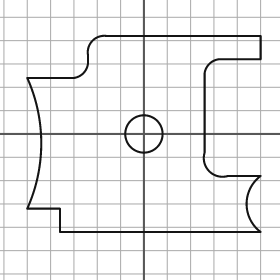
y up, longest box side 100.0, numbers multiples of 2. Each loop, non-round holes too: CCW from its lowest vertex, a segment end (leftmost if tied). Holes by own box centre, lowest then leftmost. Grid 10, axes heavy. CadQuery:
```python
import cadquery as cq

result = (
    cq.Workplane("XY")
    .moveTo(-36.0, -42.0)
    .lineTo(50.0, -42.0)
    .threePointArc((44.0, -30.0), (50.0, -18.0))
    .lineTo(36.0, -18.0)
    .threePointArc((28.0, -16.0), (26.0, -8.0))
    .lineTo(26.0, 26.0)
    .threePointArc((28.0, 30.0), (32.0, 32.0))
    .lineTo(50.0, 32.0)
    .lineTo(50.0, 42.0)
    .lineTo(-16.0, 42.0)
    .threePointArc((-22.0, 40.0), (-24.0, 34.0))
    .lineTo(-24.0, 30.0)
    .threePointArc((-26.0, 26.0), (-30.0, 24.0))
    .lineTo(-50.0, 24.0)
    .threePointArc((-44.0, -4.0), (-50.0, -32.0))
    .lineTo(-36.0, -32.0)
    .close()
    .moveTo(0.0, 0.0)
    .circle(8.0)
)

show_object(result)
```